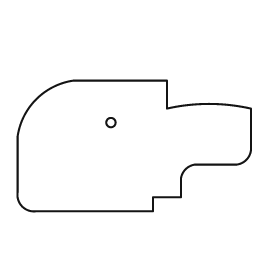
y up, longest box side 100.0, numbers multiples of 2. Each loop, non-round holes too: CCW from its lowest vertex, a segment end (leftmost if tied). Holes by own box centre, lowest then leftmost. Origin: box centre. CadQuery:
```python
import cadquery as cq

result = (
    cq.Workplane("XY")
    .moveTo(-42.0, -28.0)
    .lineTo(8.0, -28.0)
    .lineTo(8.0, -22.0)
    .lineTo(20.0, -22.0)
    .lineTo(20.0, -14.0)
    .threePointArc((22.0, -10.0), (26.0, -8.0))
    .lineTo(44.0, -8.0)
    .threePointArc((48.0, -6.0), (50.0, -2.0))
    .lineTo(50.0, 16.0)
    .threePointArc((32.0, 18.0), (14.0, 16.0))
    .lineTo(14.0, 28.0)
    .lineTo(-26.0, 28.0)
    .threePointArc((-42.0, 20.0), (-50.0, 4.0))
    .lineTo(-50.0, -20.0)
    .threePointArc((-48.0, -26.0), (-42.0, -28.0))
    .close()
    .moveTo(-10.0, 10.0)
    .circle(2.0)
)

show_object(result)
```